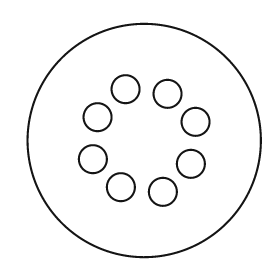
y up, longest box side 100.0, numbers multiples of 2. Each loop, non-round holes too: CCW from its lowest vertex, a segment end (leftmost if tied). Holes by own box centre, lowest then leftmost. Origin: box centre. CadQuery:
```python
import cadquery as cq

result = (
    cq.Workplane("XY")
    .moveTo(0.0, 0.0)
    .circle(50.0)
    .moveTo(8.0, -22.0)
    .circle(6.0)
    .moveTo(-10.0, -20.0)
    .circle(6.0)
    .moveTo(20.0, -10.0)
    .circle(6.0)
    .moveTo(-22.0, -8.0)
    .circle(6.0)
    .moveTo(22.0, 8.0)
    .circle(6.0)
    .moveTo(-20.0, 10.0)
    .circle(6.0)
    .moveTo(10.0, 20.0)
    .circle(6.0)
    .moveTo(-8.0, 22.0)
    .circle(6.0)
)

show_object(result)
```